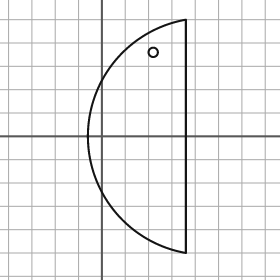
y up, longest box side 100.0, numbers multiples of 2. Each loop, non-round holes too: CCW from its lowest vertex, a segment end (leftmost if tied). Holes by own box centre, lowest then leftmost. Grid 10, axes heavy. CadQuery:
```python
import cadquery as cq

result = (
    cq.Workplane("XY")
    .moveTo(36.0, -50.0)
    .lineTo(36.0, 50.0)
    .threePointArc((-6.0, 0.0), (36.0, -50.0))
    .close()
    .moveTo(22.0, 36.0)
    .circle(2.0)
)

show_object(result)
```